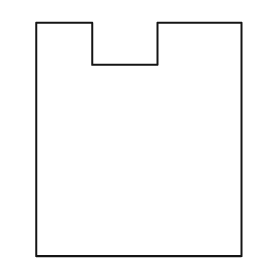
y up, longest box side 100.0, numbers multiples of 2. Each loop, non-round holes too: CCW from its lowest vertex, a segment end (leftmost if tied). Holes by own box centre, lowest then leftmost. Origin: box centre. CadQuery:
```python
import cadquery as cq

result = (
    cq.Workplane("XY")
    .moveTo(-44.0, -50.0)
    .lineTo(44.0, -50.0)
    .lineTo(44.0, 50.0)
    .lineTo(8.0, 50.0)
    .lineTo(8.0, 32.0)
    .lineTo(-20.0, 32.0)
    .lineTo(-20.0, 50.0)
    .lineTo(-44.0, 50.0)
    .close()
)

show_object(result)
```